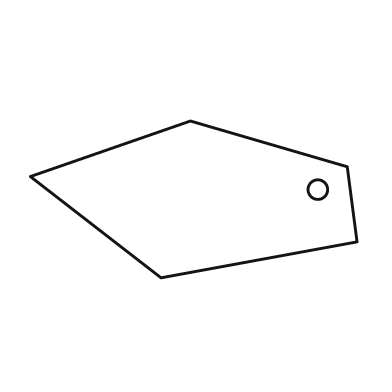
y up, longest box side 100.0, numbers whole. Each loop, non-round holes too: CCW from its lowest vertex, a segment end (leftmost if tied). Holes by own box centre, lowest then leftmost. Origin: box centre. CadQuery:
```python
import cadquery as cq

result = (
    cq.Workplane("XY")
    .moveTo(-10.0, -24.0)
    .lineTo(50.0, -13.0)
    .lineTo(47.0, 10.0)
    .lineTo(-1.0, 24.0)
    .lineTo(-50.0, 7.0)
    .close()
    .moveTo(38.0, 3.0)
    .circle(3.0)
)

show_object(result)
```